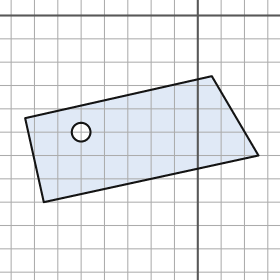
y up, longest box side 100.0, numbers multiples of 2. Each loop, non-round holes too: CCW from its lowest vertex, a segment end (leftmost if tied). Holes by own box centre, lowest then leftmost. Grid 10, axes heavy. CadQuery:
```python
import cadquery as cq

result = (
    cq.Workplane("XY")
    .moveTo(-66.0, -80.0)
    .lineTo(26.0, -60.0)
    .lineTo(6.0, -26.0)
    .lineTo(-74.0, -44.0)
    .close()
    .moveTo(-50.0, -50.0)
    .circle(4.0)
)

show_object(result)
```